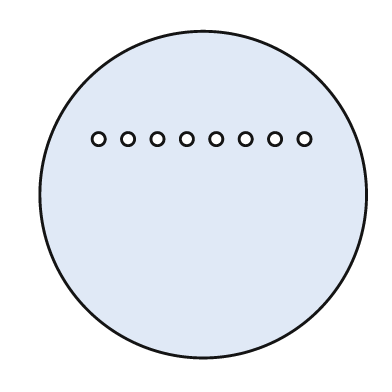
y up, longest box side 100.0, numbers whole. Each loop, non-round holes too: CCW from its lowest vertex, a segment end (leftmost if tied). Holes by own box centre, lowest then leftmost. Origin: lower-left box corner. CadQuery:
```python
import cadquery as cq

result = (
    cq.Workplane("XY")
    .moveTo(50.0, 50.0)
    .circle(50.0)
    .moveTo(18.0, 67.0)
    .circle(2.0)
    .moveTo(27.0, 67.0)
    .circle(2.0)
    .moveTo(36.0, 67.0)
    .circle(2.0)
    .moveTo(45.0, 67.0)
    .circle(2.0)
    .moveTo(54.0, 67.0)
    .circle(2.0)
    .moveTo(63.0, 67.0)
    .circle(2.0)
    .moveTo(72.0, 67.0)
    .circle(2.0)
    .moveTo(81.0, 67.0)
    .circle(2.0)
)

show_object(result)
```